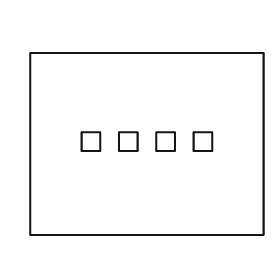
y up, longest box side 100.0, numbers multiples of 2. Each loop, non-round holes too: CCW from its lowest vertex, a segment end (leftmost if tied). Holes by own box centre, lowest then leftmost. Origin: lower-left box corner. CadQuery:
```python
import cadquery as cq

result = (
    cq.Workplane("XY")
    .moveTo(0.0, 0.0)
    .lineTo(100.0, 0.0)
    .lineTo(100.0, 78.0)
    .lineTo(0.0, 78.0)
    .close()
    .moveTo(22.0, 36.0)
    .lineTo(30.0, 36.0)
    .lineTo(30.0, 44.0)
    .lineTo(22.0, 44.0)
    .close()
    .moveTo(38.0, 36.0)
    .lineTo(46.0, 36.0)
    .lineTo(46.0, 44.0)
    .lineTo(38.0, 44.0)
    .close()
    .moveTo(54.0, 36.0)
    .lineTo(62.0, 36.0)
    .lineTo(62.0, 44.0)
    .lineTo(54.0, 44.0)
    .close()
    .moveTo(70.0, 36.0)
    .lineTo(78.0, 36.0)
    .lineTo(78.0, 44.0)
    .lineTo(70.0, 44.0)
    .close()
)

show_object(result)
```